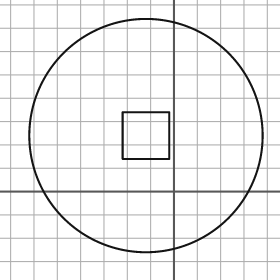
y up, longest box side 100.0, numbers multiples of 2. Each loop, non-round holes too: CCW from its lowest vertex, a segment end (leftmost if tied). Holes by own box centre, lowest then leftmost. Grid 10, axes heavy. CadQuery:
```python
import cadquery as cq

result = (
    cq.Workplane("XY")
    .moveTo(-12.0, 24.0)
    .circle(50.0)
    .moveTo(-22.0, 14.0)
    .lineTo(-2.0, 14.0)
    .lineTo(-2.0, 34.0)
    .lineTo(-22.0, 34.0)
    .close()
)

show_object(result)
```